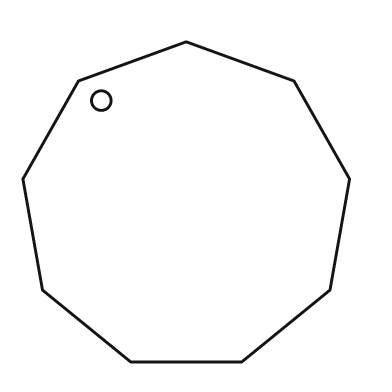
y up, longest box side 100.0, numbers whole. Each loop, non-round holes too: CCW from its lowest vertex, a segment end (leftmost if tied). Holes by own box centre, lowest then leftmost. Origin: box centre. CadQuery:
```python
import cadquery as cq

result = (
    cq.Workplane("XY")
    .moveTo(-17.0, -49.0)
    .lineTo(17.0, -49.0)
    .lineTo(44.0, -27.0)
    .lineTo(50.0, 7.0)
    .lineTo(33.0, 37.0)
    .lineTo(0.0, 49.0)
    .lineTo(-33.0, 37.0)
    .lineTo(-50.0, 7.0)
    .lineTo(-44.0, -27.0)
    .close()
    .moveTo(-26.0, 31.0)
    .circle(3.0)
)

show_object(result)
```